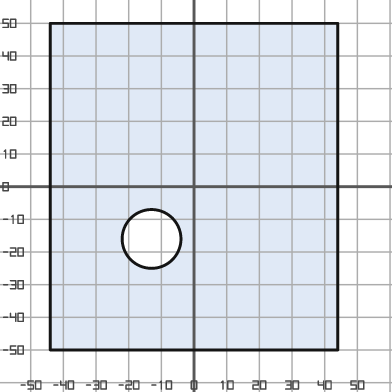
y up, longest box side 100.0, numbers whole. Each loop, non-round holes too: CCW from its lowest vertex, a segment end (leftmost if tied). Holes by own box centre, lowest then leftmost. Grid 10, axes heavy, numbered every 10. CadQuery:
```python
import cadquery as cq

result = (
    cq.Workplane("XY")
    .moveTo(-44.0, -50.0)
    .lineTo(44.0, -50.0)
    .lineTo(44.0, 50.0)
    .lineTo(-44.0, 50.0)
    .close()
    .moveTo(-13.0, -16.0)
    .circle(9.0)
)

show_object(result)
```